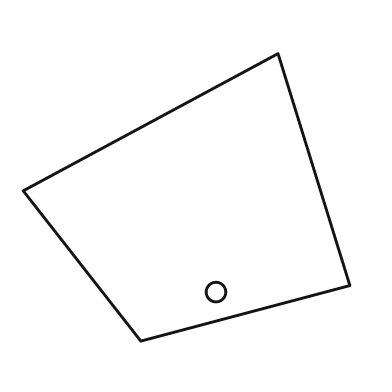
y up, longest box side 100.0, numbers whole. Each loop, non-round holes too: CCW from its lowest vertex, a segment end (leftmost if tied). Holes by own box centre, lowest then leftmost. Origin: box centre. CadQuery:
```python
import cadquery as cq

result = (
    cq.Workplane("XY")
    .moveTo(-14.0, -44.0)
    .lineTo(50.0, -27.0)
    .lineTo(28.0, 44.0)
    .lineTo(-50.0, 2.0)
    .close()
    .moveTo(9.0, -29.0)
    .circle(3.0)
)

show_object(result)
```